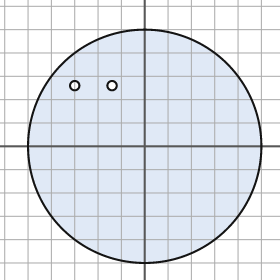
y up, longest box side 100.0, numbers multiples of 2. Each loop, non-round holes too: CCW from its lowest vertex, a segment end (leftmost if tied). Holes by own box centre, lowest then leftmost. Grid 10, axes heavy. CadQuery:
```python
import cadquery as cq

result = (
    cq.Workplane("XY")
    .moveTo(0.0, 0.0)
    .circle(50.0)
    .moveTo(-30.0, 26.0)
    .circle(2.0)
    .moveTo(-14.0, 26.0)
    .circle(2.0)
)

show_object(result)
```